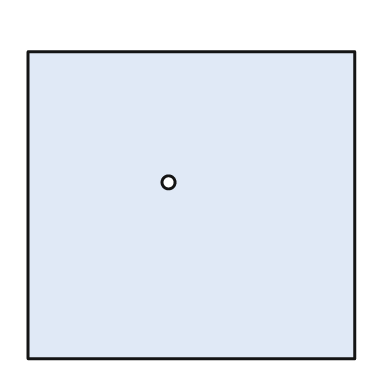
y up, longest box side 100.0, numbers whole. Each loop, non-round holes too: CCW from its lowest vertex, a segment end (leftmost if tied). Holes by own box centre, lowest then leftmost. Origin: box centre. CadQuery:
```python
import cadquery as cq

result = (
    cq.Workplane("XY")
    .moveTo(-50.0, -47.0)
    .lineTo(50.0, -47.0)
    .lineTo(50.0, 47.0)
    .lineTo(-50.0, 47.0)
    .close()
    .moveTo(-7.0, 7.0)
    .circle(2.0)
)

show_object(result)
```